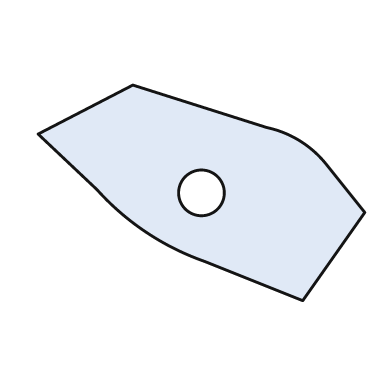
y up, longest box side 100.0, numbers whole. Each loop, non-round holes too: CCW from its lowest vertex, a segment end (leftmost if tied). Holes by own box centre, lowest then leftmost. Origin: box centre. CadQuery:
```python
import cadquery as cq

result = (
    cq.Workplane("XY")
    .moveTo(31.0, -33.0)
    .lineTo(50.0, -6.0)
    .lineTo(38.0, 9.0)
    .threePointArc((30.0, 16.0), (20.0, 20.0))
    .lineTo(-21.0, 33.0)
    .lineTo(-50.0, 18.0)
    .lineTo(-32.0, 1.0)
    .threePointArc((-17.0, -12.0), (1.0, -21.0))
    .close()
    .moveTo(0.0, 0.0)
    .circle(7.0)
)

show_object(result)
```